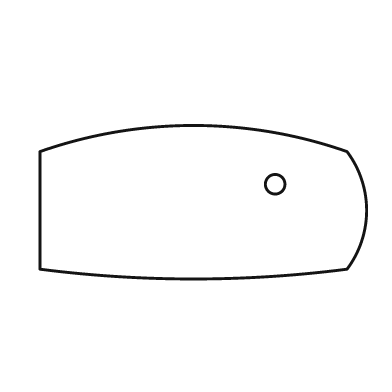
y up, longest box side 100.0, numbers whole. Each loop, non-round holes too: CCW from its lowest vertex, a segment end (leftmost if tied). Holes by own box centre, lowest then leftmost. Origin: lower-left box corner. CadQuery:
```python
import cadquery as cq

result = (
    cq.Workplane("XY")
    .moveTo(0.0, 3.0)
    .threePointArc((47.0, 0.0), (94.0, 3.0))
    .threePointArc((100.0, 21.0), (94.0, 39.0))
    .threePointArc((47.0, 47.0), (0.0, 39.0))
    .close()
    .moveTo(72.0, 29.0)
    .circle(3.0)
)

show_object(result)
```